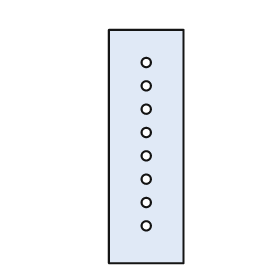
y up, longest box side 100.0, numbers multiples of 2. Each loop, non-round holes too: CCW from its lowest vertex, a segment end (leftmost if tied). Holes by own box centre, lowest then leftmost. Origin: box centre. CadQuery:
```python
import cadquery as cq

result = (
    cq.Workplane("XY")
    .moveTo(-16.0, -50.0)
    .lineTo(16.0, -50.0)
    .lineTo(16.0, 50.0)
    .lineTo(-16.0, 50.0)
    .close()
    .moveTo(0.0, -34.0)
    .circle(2.0)
    .moveTo(0.0, -24.0)
    .circle(2.0)
    .moveTo(0.0, -14.0)
    .circle(2.0)
    .moveTo(0.0, -4.0)
    .circle(2.0)
    .moveTo(0.0, 6.0)
    .circle(2.0)
    .moveTo(0.0, 16.0)
    .circle(2.0)
    .moveTo(0.0, 26.0)
    .circle(2.0)
    .moveTo(0.0, 36.0)
    .circle(2.0)
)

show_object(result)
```